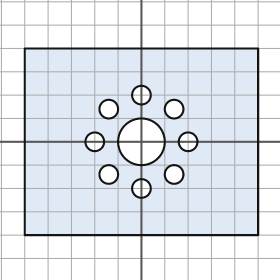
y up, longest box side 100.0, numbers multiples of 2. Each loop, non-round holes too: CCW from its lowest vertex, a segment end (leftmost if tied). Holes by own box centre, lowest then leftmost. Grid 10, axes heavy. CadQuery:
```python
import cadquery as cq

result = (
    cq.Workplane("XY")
    .moveTo(-50.0, -40.0)
    .lineTo(50.0, -40.0)
    .lineTo(50.0, 40.0)
    .lineTo(-50.0, 40.0)
    .close()
    .moveTo(0.0, -20.0)
    .circle(4.0)
    .moveTo(-14.0, -14.0)
    .circle(4.0)
    .moveTo(14.0, -14.0)
    .circle(4.0)
    .moveTo(-20.0, 0.0)
    .circle(4.0)
    .moveTo(0.0, 0.0)
    .circle(10.0)
    .moveTo(20.0, 0.0)
    .circle(4.0)
    .moveTo(-14.0, 14.0)
    .circle(4.0)
    .moveTo(14.0, 14.0)
    .circle(4.0)
    .moveTo(0.0, 20.0)
    .circle(4.0)
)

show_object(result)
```